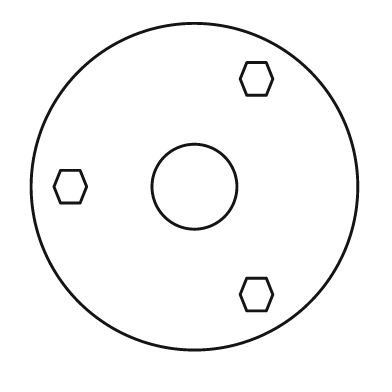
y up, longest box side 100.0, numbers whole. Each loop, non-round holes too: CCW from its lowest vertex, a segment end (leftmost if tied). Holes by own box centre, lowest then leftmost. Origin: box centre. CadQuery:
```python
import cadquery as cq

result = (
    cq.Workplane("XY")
    .moveTo(0.0, 0.0)
    .circle(50.0)
    .moveTo(16.0, -38.0)
    .lineTo(22.0, -38.0)
    .lineTo(24.0, -33.0)
    .lineTo(22.0, -28.0)
    .lineTo(16.0, -28.0)
    .lineTo(14.0, -33.0)
    .close()
    .moveTo(-41.0, -5.0)
    .lineTo(-35.0, -5.0)
    .lineTo(-33.0, 0.0)
    .lineTo(-35.0, 5.0)
    .lineTo(-41.0, 5.0)
    .lineTo(-43.0, 0.0)
    .close()
    .moveTo(0.0, 0.0)
    .circle(13.0)
    .moveTo(16.0, 28.0)
    .lineTo(22.0, 28.0)
    .lineTo(24.0, 33.0)
    .lineTo(22.0, 38.0)
    .lineTo(16.0, 38.0)
    .lineTo(14.0, 33.0)
    .close()
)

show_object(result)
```